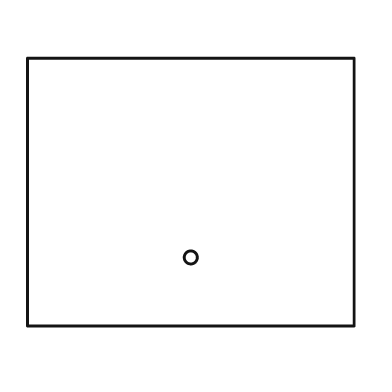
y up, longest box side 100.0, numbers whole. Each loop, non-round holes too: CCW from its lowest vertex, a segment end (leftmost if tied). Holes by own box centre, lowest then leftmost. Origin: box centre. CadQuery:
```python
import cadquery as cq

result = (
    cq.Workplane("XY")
    .moveTo(-50.0, -41.0)
    .lineTo(50.0, -41.0)
    .lineTo(50.0, 41.0)
    .lineTo(-50.0, 41.0)
    .close()
    .moveTo(0.0, -20.0)
    .circle(2.0)
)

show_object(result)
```